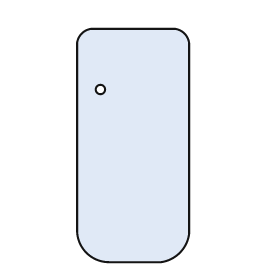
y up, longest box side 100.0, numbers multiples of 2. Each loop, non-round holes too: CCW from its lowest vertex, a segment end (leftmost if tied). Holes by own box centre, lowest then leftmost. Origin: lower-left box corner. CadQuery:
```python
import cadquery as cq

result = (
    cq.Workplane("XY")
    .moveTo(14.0, 0.0)
    .lineTo(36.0, 0.0)
    .threePointArc((44.0, 4.0), (48.0, 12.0))
    .lineTo(48.0, 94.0)
    .threePointArc((46.0, 98.0), (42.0, 100.0))
    .lineTo(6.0, 100.0)
    .threePointArc((2.0, 98.0), (0.0, 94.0))
    .lineTo(0.0, 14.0)
    .threePointArc((4.0, 4.0), (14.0, 0.0))
    .close()
    .moveTo(10.0, 74.0)
    .circle(2.0)
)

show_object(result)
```